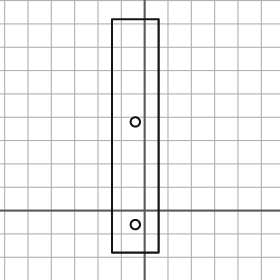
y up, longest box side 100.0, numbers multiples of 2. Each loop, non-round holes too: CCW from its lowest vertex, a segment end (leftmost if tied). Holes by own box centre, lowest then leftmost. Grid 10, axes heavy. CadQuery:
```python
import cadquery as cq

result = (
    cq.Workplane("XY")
    .moveTo(-14.0, -18.0)
    .lineTo(6.0, -18.0)
    .lineTo(6.0, 82.0)
    .lineTo(-14.0, 82.0)
    .close()
    .moveTo(-4.0, -6.0)
    .circle(2.0)
    .moveTo(-4.0, 38.0)
    .circle(2.0)
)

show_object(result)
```